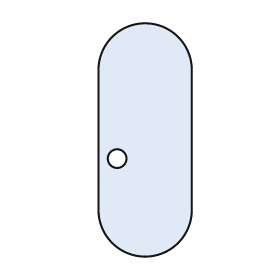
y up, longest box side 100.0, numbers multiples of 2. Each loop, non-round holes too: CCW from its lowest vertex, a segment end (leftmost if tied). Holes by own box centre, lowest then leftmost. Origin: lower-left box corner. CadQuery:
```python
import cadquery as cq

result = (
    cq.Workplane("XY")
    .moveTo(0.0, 20.0)
    .threePointArc((20.0, 0.0), (40.0, 20.0))
    .lineTo(40.0, 80.0)
    .threePointArc((20.0, 100.0), (0.0, 80.0))
    .close()
    .moveTo(8.0, 42.0)
    .circle(4.0)
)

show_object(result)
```